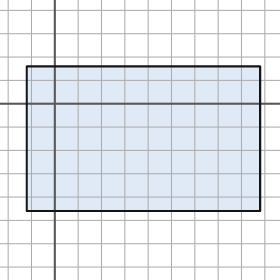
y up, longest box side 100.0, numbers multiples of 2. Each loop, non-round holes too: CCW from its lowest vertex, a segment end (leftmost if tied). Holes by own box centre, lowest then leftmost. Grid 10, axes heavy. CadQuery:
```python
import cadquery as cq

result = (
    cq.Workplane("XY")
    .moveTo(-12.0, -46.0)
    .lineTo(88.0, -46.0)
    .lineTo(88.0, 16.0)
    .lineTo(-12.0, 16.0)
    .close()
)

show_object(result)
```